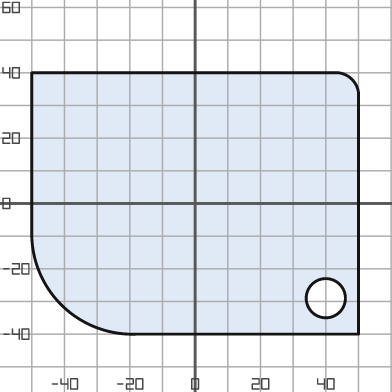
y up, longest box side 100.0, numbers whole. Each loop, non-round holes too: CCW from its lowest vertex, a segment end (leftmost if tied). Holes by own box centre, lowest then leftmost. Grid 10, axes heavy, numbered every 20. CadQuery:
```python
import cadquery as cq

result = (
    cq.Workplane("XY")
    .moveTo(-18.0, -40.0)
    .lineTo(50.0, -40.0)
    .lineTo(50.0, 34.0)
    .threePointArc((48.0, 38.0), (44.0, 40.0))
    .lineTo(-50.0, 40.0)
    .lineTo(-50.0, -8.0)
    .threePointArc((-41.0, -31.0), (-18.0, -40.0))
    .close()
    .moveTo(40.0, -29.0)
    .circle(6.0)
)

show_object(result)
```